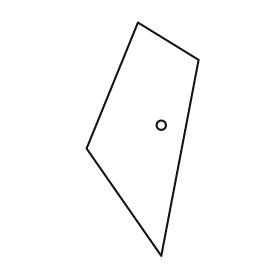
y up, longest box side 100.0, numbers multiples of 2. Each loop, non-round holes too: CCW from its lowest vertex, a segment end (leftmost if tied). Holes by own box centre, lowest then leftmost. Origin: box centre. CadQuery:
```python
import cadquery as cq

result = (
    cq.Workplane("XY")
    .moveTo(8.0, -50.0)
    .lineTo(24.0, 34.0)
    .lineTo(-2.0, 50.0)
    .lineTo(-24.0, -4.0)
    .close()
    .moveTo(8.0, 6.0)
    .circle(2.0)
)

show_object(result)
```